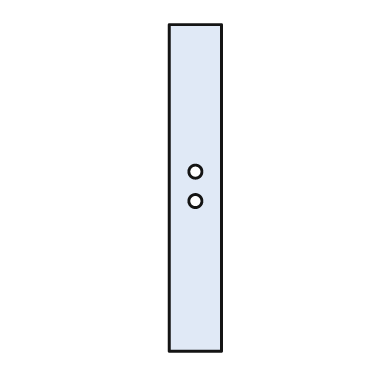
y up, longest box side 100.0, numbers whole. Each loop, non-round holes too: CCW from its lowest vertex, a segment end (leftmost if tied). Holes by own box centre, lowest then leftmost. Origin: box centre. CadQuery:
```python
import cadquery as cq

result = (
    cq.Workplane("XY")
    .moveTo(-8.0, -50.0)
    .lineTo(8.0, -50.0)
    .lineTo(8.0, 50.0)
    .lineTo(-8.0, 50.0)
    .close()
    .moveTo(0.0, -4.0)
    .circle(2.0)
    .moveTo(0.0, 5.0)
    .circle(2.0)
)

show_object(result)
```